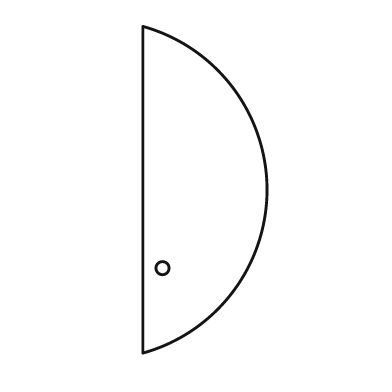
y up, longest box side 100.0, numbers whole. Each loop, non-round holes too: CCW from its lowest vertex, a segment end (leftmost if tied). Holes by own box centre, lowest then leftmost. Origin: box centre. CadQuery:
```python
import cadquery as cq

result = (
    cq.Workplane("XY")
    .moveTo(-19.0, -50.0)
    .threePointArc((19.0, 0.0), (-19.0, 50.0))
    .close()
    .moveTo(-13.0, -24.0)
    .circle(2.0)
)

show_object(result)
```